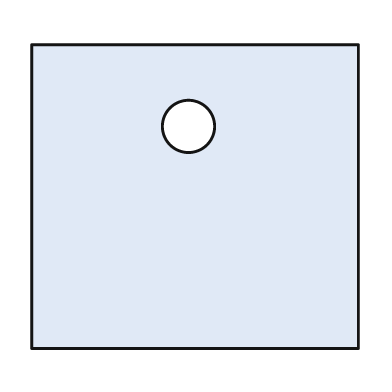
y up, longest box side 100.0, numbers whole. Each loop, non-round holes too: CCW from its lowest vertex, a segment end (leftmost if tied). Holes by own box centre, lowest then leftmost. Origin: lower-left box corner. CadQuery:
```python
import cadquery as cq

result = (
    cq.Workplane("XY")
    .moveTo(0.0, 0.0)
    .lineTo(100.0, 0.0)
    .lineTo(100.0, 93.0)
    .lineTo(0.0, 93.0)
    .close()
    .moveTo(48.0, 68.0)
    .circle(8.0)
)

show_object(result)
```